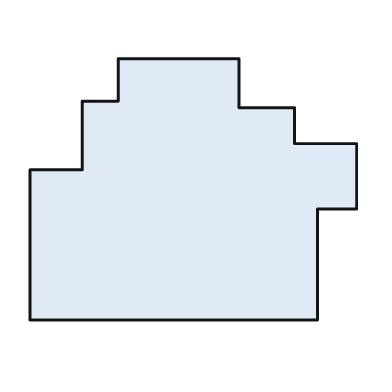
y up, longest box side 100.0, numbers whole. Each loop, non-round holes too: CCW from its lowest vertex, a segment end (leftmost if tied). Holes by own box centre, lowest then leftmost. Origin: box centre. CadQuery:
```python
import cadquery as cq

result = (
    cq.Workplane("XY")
    .moveTo(-50.0, -40.0)
    .lineTo(38.0, -40.0)
    .lineTo(38.0, -6.0)
    .lineTo(50.0, -6.0)
    .lineTo(50.0, 14.0)
    .lineTo(31.0, 14.0)
    .lineTo(31.0, 25.0)
    .lineTo(14.0, 25.0)
    .lineTo(14.0, 40.0)
    .lineTo(-23.0, 40.0)
    .lineTo(-23.0, 27.0)
    .lineTo(-34.0, 27.0)
    .lineTo(-34.0, 6.0)
    .lineTo(-50.0, 6.0)
    .close()
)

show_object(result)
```